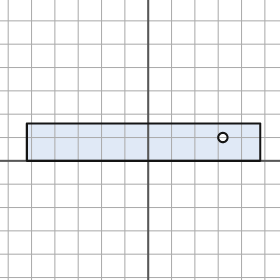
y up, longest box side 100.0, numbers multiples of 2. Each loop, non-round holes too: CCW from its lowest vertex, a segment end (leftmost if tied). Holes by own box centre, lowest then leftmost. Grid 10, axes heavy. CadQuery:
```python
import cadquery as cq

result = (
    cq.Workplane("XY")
    .moveTo(-52.0, 0.0)
    .lineTo(48.0, 0.0)
    .lineTo(48.0, 16.0)
    .lineTo(-52.0, 16.0)
    .close()
    .moveTo(32.0, 10.0)
    .circle(2.0)
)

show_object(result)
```